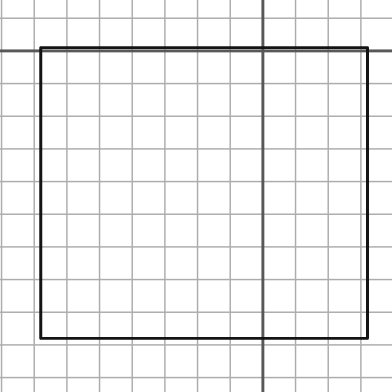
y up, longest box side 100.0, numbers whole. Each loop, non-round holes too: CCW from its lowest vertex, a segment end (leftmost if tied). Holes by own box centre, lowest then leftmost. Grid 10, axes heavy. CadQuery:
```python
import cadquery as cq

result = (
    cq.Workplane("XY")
    .moveTo(-68.0, -88.0)
    .lineTo(32.0, -88.0)
    .lineTo(32.0, 1.0)
    .lineTo(-68.0, 1.0)
    .close()
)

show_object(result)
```